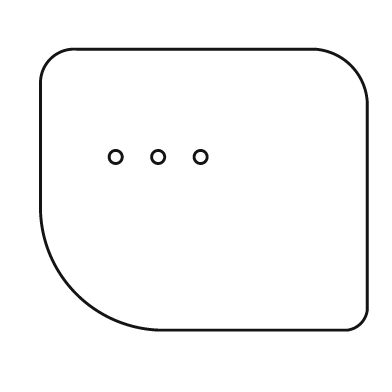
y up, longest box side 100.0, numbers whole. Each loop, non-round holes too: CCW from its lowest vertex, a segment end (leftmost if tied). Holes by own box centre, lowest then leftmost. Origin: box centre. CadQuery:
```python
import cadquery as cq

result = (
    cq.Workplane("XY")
    .moveTo(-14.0, -43.0)
    .lineTo(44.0, -43.0)
    .threePointArc((48.0, -41.0), (50.0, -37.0))
    .lineTo(50.0, 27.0)
    .threePointArc((45.0, 38.0), (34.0, 43.0))
    .lineTo(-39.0, 43.0)
    .threePointArc((-47.0, 40.0), (-50.0, 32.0))
    .lineTo(-50.0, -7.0)
    .threePointArc((-39.0, -32.0), (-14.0, -43.0))
    .close()
    .moveTo(-27.0, 10.0)
    .circle(2.0)
    .moveTo(-14.0, 10.0)
    .circle(2.0)
    .moveTo(-1.0, 10.0)
    .circle(2.0)
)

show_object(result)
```